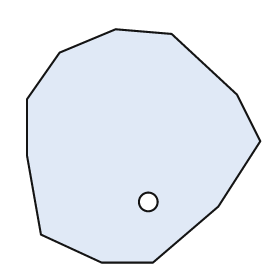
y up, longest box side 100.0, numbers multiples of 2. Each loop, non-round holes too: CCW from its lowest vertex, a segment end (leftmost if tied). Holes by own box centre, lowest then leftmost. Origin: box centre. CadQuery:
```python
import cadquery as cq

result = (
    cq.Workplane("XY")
    .moveTo(-18.0, -50.0)
    .lineTo(4.0, -50.0)
    .lineTo(32.0, -26.0)
    .lineTo(50.0, 2.0)
    .lineTo(40.0, 22.0)
    .lineTo(12.0, 48.0)
    .lineTo(-12.0, 50.0)
    .lineTo(-36.0, 40.0)
    .lineTo(-50.0, 20.0)
    .lineTo(-50.0, -4.0)
    .lineTo(-44.0, -38.0)
    .close()
    .moveTo(2.0, -24.0)
    .circle(4.0)
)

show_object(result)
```